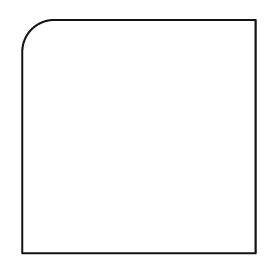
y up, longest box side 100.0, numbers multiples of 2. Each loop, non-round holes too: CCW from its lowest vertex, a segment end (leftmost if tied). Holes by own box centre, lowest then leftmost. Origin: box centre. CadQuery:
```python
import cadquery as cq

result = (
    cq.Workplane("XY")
    .moveTo(-50.0, -50.0)
    .lineTo(50.0, -50.0)
    .lineTo(50.0, 50.0)
    .lineTo(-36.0, 50.0)
    .threePointArc((-46.0, 46.0), (-50.0, 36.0))
    .close()
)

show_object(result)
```